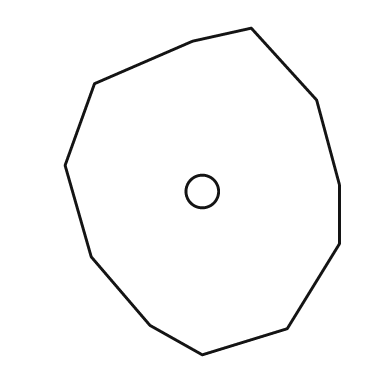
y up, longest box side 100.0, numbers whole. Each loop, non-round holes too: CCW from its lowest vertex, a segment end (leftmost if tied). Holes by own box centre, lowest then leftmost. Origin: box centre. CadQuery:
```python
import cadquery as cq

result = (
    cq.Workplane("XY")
    .moveTo(0.0, -50.0)
    .lineTo(26.0, -42.0)
    .lineTo(42.0, -16.0)
    .lineTo(42.0, 2.0)
    .lineTo(35.0, 28.0)
    .lineTo(15.0, 50.0)
    .lineTo(-3.0, 46.0)
    .lineTo(-33.0, 33.0)
    .lineTo(-42.0, 8.0)
    .lineTo(-34.0, -20.0)
    .lineTo(-16.0, -41.0)
    .close()
    .moveTo(0.0, 0.0)
    .circle(5.0)
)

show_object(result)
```